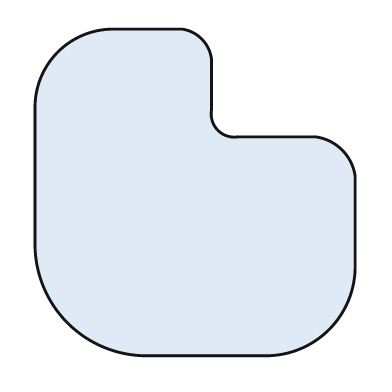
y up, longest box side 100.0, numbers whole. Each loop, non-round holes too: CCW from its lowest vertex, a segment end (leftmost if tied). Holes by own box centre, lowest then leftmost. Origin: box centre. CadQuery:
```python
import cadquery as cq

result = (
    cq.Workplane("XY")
    .moveTo(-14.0, -50.0)
    .lineTo(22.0, -50.0)
    .threePointArc((41.0, -42.0), (49.0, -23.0))
    .lineTo(49.0, 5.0)
    .threePointArc((45.0, 13.0), (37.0, 17.0))
    .lineTo(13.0, 17.0)
    .threePointArc((7.0, 19.0), (5.0, 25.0))
    .lineTo(5.0, 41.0)
    .threePointArc((2.0, 47.0), (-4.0, 50.0))
    .lineTo(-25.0, 50.0)
    .threePointArc((-42.0, 43.0), (-49.0, 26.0))
    .lineTo(-49.0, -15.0)
    .threePointArc((-39.0, -40.0), (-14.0, -50.0))
    .close()
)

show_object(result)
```